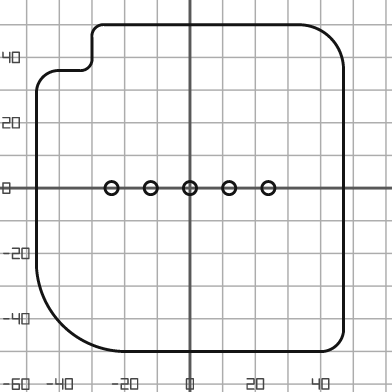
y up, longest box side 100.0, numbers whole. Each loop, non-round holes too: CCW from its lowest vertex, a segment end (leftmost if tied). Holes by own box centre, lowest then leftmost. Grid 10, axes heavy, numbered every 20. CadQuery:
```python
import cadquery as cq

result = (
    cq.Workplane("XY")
    .moveTo(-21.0, -50.0)
    .lineTo(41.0, -50.0)
    .threePointArc((45.0, -48.0), (47.0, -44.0))
    .lineTo(47.0, 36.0)
    .threePointArc((43.0, 46.0), (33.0, 50.0))
    .lineTo(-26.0, 50.0)
    .threePointArc((-29.0, 49.0), (-30.0, 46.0))
    .lineTo(-30.0, 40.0)
    .threePointArc((-31.0, 37.0), (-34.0, 36.0))
    .lineTo(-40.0, 36.0)
    .threePointArc((-45.0, 34.0), (-47.0, 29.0))
    .lineTo(-47.0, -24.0)
    .threePointArc((-39.0, -42.0), (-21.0, -50.0))
    .close()
    .moveTo(-24.0, 0.0)
    .circle(2.0)
    .moveTo(-12.0, 0.0)
    .circle(2.0)
    .moveTo(0.0, 0.0)
    .circle(2.0)
    .moveTo(12.0, 0.0)
    .circle(2.0)
    .moveTo(24.0, 0.0)
    .circle(2.0)
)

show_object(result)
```